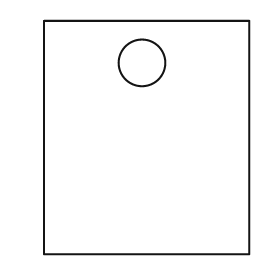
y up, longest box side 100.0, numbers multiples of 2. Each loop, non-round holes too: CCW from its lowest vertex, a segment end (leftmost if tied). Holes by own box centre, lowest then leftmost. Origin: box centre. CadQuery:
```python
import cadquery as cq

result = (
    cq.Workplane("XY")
    .moveTo(-44.0, -50.0)
    .lineTo(44.0, -50.0)
    .lineTo(44.0, 50.0)
    .lineTo(-44.0, 50.0)
    .close()
    .moveTo(-2.0, 32.0)
    .circle(10.0)
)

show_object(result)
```